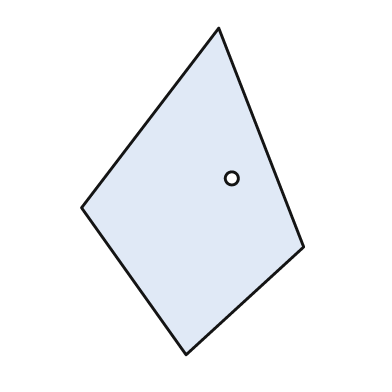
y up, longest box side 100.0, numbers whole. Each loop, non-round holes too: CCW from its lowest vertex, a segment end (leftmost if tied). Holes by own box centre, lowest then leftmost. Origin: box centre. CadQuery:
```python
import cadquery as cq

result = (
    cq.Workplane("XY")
    .moveTo(-2.0, -50.0)
    .lineTo(34.0, -17.0)
    .lineTo(8.0, 50.0)
    .lineTo(-34.0, -5.0)
    .close()
    .moveTo(12.0, 4.0)
    .circle(2.0)
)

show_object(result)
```